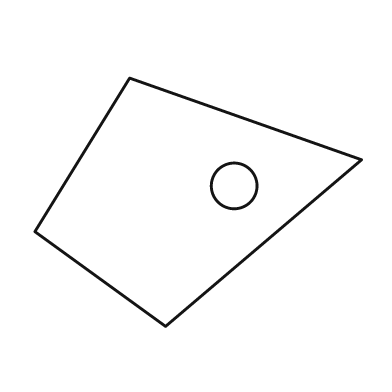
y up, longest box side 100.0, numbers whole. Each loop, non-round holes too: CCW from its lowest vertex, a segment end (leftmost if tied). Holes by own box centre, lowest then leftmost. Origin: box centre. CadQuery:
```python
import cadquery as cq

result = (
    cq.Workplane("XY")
    .moveTo(-10.0, -38.0)
    .lineTo(50.0, 13.0)
    .lineTo(-21.0, 38.0)
    .lineTo(-50.0, -9.0)
    .close()
    .moveTo(11.0, 5.0)
    .circle(7.0)
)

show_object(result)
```